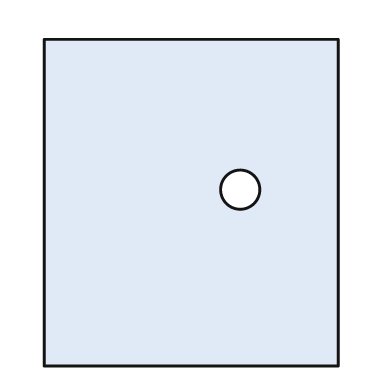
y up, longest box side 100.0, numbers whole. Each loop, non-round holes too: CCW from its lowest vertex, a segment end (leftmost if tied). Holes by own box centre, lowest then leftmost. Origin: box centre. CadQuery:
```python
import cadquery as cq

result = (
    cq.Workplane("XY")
    .moveTo(-45.0, -50.0)
    .lineTo(45.0, -50.0)
    .lineTo(45.0, 50.0)
    .lineTo(-45.0, 50.0)
    .close()
    .moveTo(15.0, 4.0)
    .circle(6.0)
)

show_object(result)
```